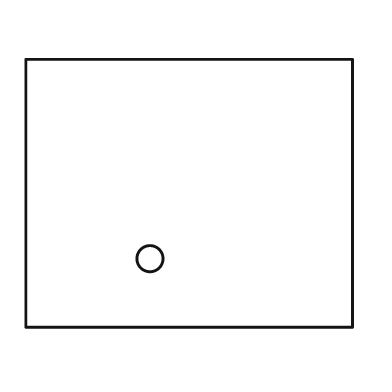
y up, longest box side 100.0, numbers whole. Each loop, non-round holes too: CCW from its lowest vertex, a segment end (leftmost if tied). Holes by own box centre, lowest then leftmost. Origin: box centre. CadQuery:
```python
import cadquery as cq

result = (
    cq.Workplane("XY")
    .moveTo(-50.0, -41.0)
    .lineTo(50.0, -41.0)
    .lineTo(50.0, 41.0)
    .lineTo(-50.0, 41.0)
    .close()
    .moveTo(-12.0, -20.0)
    .circle(4.0)
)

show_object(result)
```